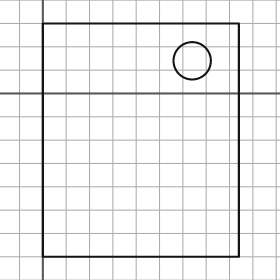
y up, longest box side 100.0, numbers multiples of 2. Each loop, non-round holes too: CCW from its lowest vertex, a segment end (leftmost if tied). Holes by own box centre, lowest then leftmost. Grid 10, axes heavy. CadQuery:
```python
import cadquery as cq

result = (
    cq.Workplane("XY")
    .moveTo(0.0, -70.0)
    .lineTo(84.0, -70.0)
    .lineTo(84.0, 30.0)
    .lineTo(0.0, 30.0)
    .close()
    .moveTo(64.0, 14.0)
    .circle(8.0)
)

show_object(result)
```